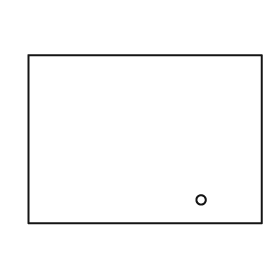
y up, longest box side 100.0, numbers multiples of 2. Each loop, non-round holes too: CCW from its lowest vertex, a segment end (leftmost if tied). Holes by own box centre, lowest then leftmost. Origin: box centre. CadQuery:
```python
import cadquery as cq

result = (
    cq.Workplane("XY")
    .moveTo(-50.0, -36.0)
    .lineTo(50.0, -36.0)
    .lineTo(50.0, 36.0)
    .lineTo(-50.0, 36.0)
    .close()
    .moveTo(24.0, -26.0)
    .circle(2.0)
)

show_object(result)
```